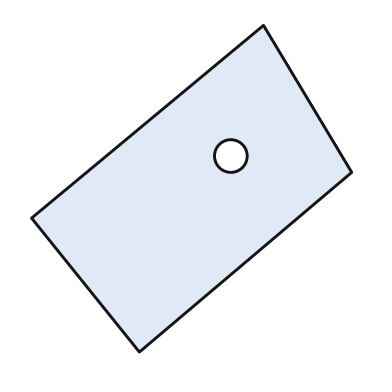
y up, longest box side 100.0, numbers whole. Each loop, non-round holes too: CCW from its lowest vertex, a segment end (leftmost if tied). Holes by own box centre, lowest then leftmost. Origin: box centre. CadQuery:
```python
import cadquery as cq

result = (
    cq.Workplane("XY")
    .moveTo(-16.0, -50.0)
    .lineTo(49.0, 5.0)
    .lineTo(22.0, 50.0)
    .lineTo(-49.0, -9.0)
    .close()
    .moveTo(12.0, 10.0)
    .circle(5.0)
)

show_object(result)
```